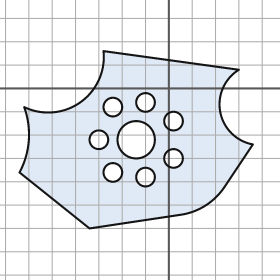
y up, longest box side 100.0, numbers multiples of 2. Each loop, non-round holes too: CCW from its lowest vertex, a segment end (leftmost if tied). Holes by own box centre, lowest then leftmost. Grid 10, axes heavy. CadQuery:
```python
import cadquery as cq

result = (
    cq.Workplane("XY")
    .moveTo(-34.0, -60.0)
    .lineTo(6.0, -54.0)
    .threePointArc((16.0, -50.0), (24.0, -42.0))
    .lineTo(36.0, -24.0)
    .threePointArc((22.0, -10.0), (30.0, 8.0))
    .lineTo(-28.0, 16.0)
    .threePointArc((-38.0, -6.0), (-62.0, -8.0))
    .threePointArc((-60.0, -22.0), (-64.0, -36.0))
    .close()
    .moveTo(-10.0, -38.0)
    .circle(4.0)
    .moveTo(-24.0, -36.0)
    .circle(4.0)
    .moveTo(2.0, -30.0)
    .circle(4.0)
    .moveTo(-30.0, -22.0)
    .circle(4.0)
    .moveTo(-14.0, -22.0)
    .circle(8.0)
    .moveTo(2.0, -14.0)
    .circle(4.0)
    .moveTo(-24.0, -8.0)
    .circle(4.0)
    .moveTo(-10.0, -6.0)
    .circle(4.0)
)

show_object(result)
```